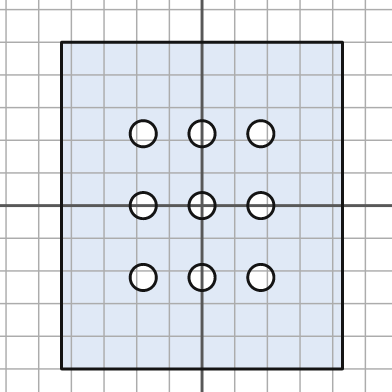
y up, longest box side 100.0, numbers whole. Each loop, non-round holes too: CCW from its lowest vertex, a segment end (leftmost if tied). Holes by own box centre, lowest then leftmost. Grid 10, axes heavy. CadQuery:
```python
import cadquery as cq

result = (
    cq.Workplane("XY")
    .moveTo(-43.0, -50.0)
    .lineTo(43.0, -50.0)
    .lineTo(43.0, 50.0)
    .lineTo(-43.0, 50.0)
    .close()
    .moveTo(-18.0, -22.0)
    .circle(4.0)
    .moveTo(0.0, -22.0)
    .circle(4.0)
    .moveTo(18.0, -22.0)
    .circle(4.0)
    .moveTo(-18.0, 0.0)
    .circle(4.0)
    .moveTo(0.0, 0.0)
    .circle(4.0)
    .moveTo(18.0, 0.0)
    .circle(4.0)
    .moveTo(-18.0, 22.0)
    .circle(4.0)
    .moveTo(0.0, 22.0)
    .circle(4.0)
    .moveTo(18.0, 22.0)
    .circle(4.0)
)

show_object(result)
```